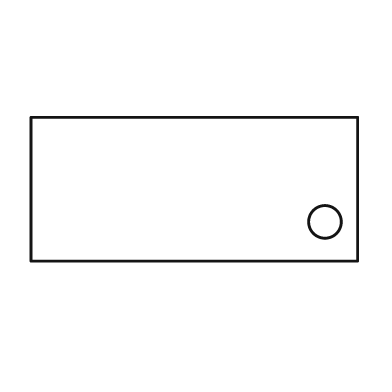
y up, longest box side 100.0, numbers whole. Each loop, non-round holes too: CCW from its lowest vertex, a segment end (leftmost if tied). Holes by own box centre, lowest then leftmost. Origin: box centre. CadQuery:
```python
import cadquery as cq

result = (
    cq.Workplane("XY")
    .moveTo(-50.0, -22.0)
    .lineTo(50.0, -22.0)
    .lineTo(50.0, 22.0)
    .lineTo(-50.0, 22.0)
    .close()
    .moveTo(40.0, -10.0)
    .circle(5.0)
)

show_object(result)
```